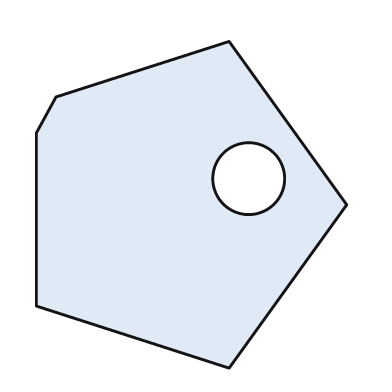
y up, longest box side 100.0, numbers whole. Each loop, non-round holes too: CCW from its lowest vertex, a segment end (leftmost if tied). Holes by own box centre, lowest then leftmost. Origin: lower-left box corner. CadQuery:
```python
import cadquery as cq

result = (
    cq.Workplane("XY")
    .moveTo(59.0, 0.0)
    .lineTo(95.0, 50.0)
    .lineTo(59.0, 100.0)
    .lineTo(6.0, 83.0)
    .lineTo(0.0, 72.0)
    .lineTo(0.0, 19.0)
    .close()
    .moveTo(65.0, 58.0)
    .circle(11.0)
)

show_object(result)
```